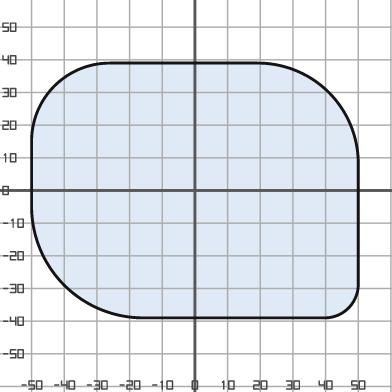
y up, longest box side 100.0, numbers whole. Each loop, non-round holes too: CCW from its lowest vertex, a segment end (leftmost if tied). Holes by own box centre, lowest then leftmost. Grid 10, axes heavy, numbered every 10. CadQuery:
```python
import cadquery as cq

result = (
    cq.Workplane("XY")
    .moveTo(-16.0, -39.0)
    .lineTo(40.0, -39.0)
    .threePointArc((47.0, -36.0), (50.0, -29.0))
    .lineTo(50.0, 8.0)
    .threePointArc((41.0, 30.0), (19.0, 39.0))
    .lineTo(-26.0, 39.0)
    .threePointArc((-43.0, 32.0), (-50.0, 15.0))
    .lineTo(-50.0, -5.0)
    .threePointArc((-40.0, -29.0), (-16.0, -39.0))
    .close()
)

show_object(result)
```